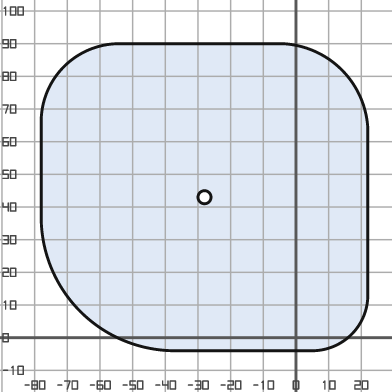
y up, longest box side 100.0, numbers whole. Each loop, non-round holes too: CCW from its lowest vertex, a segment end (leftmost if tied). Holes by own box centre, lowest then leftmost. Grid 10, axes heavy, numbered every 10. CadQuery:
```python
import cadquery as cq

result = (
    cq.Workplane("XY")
    .moveTo(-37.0, -4.0)
    .lineTo(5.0, -4.0)
    .threePointArc((17.0, 1.0), (22.0, 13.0))
    .lineTo(22.0, 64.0)
    .threePointArc((14.0, 82.0), (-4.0, 90.0))
    .lineTo(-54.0, 90.0)
    .threePointArc((-71.0, 83.0), (-78.0, 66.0))
    .lineTo(-78.0, 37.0)
    .threePointArc((-66.0, 8.0), (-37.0, -4.0))
    .close()
    .moveTo(-28.0, 43.0)
    .circle(2.0)
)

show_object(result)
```